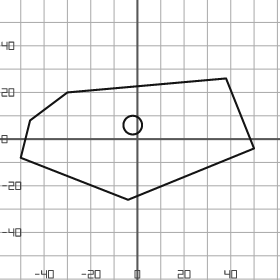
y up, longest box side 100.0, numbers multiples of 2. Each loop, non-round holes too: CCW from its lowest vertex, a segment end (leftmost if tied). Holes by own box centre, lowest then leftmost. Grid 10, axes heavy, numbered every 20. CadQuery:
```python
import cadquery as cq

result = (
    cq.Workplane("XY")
    .moveTo(-4.0, -26.0)
    .lineTo(50.0, -4.0)
    .lineTo(38.0, 26.0)
    .lineTo(-30.0, 20.0)
    .lineTo(-46.0, 8.0)
    .lineTo(-50.0, -8.0)
    .close()
    .moveTo(-2.0, 6.0)
    .circle(4.0)
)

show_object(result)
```